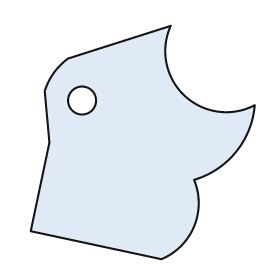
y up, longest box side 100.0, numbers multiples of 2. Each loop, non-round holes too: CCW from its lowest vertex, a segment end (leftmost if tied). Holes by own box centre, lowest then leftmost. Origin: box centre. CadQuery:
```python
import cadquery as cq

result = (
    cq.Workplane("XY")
    .moveTo(8.0, -50.0)
    .threePointArc((22.0, -36.0), (22.0, -16.0))
    .threePointArc((40.0, -4.0), (48.0, 16.0))
    .threePointArc((18.0, 20.0), (12.0, 50.0))
    .lineTo(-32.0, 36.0)
    .threePointArc((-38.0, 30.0), (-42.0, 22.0))
    .lineTo(-40.0, 0.0)
    .lineTo(-48.0, -38.0)
    .close()
    .moveTo(-26.0, 18.0)
    .circle(6.0)
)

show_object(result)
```